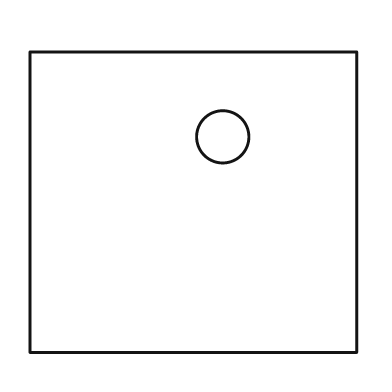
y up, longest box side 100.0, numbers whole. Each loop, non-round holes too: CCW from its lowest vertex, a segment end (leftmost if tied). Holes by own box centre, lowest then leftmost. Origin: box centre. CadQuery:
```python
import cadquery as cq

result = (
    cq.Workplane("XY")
    .moveTo(-50.0, -46.0)
    .lineTo(50.0, -46.0)
    .lineTo(50.0, 46.0)
    .lineTo(-50.0, 46.0)
    .close()
    .moveTo(9.0, 20.0)
    .circle(8.0)
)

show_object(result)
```